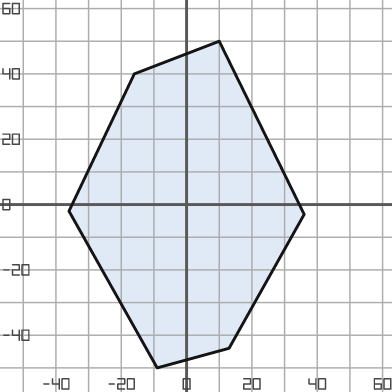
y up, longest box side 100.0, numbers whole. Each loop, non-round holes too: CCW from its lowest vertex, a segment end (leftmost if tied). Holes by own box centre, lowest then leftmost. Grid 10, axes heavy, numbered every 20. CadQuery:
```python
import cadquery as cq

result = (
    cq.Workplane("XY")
    .moveTo(-9.0, -50.0)
    .lineTo(13.0, -44.0)
    .lineTo(36.0, -3.0)
    .lineTo(10.0, 50.0)
    .lineTo(-16.0, 40.0)
    .lineTo(-36.0, -2.0)
    .close()
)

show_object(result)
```